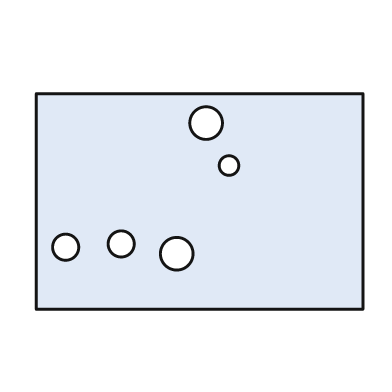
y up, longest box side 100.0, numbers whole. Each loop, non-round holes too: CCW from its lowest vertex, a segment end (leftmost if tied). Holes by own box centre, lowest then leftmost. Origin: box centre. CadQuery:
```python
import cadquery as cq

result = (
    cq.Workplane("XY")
    .moveTo(-50.0, -33.0)
    .lineTo(50.0, -33.0)
    .lineTo(50.0, 33.0)
    .lineTo(-50.0, 33.0)
    .close()
    .moveTo(-7.0, -16.0)
    .circle(5.0)
    .moveTo(-41.0, -14.0)
    .circle(4.0)
    .moveTo(-24.0, -13.0)
    .circle(4.0)
    .moveTo(9.0, 11.0)
    .circle(3.0)
    .moveTo(2.0, 24.0)
    .circle(5.0)
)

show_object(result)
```